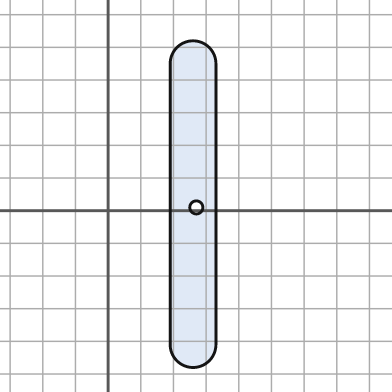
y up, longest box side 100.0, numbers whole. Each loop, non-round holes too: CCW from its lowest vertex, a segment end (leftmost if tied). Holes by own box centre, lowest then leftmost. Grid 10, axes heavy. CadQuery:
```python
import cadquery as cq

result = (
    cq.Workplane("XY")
    .moveTo(19.0, -41.0)
    .threePointArc((26.0, -48.0), (33.0, -41.0))
    .lineTo(33.0, 45.0)
    .threePointArc((26.0, 52.0), (19.0, 45.0))
    .close()
    .moveTo(27.0, 1.0)
    .circle(2.0)
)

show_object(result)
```